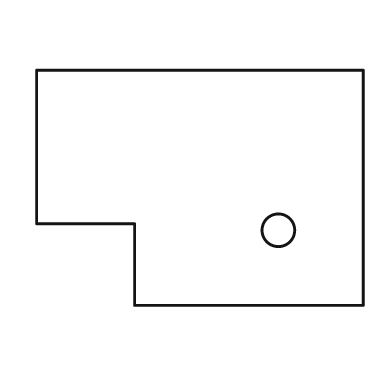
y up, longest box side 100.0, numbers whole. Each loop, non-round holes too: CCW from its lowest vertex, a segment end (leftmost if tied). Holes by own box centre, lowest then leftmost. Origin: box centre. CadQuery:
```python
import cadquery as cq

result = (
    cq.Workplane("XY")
    .moveTo(-20.0, -36.0)
    .lineTo(50.0, -36.0)
    .lineTo(50.0, 36.0)
    .lineTo(-50.0, 36.0)
    .lineTo(-50.0, -11.0)
    .lineTo(-20.0, -11.0)
    .close()
    .moveTo(24.0, -13.0)
    .circle(5.0)
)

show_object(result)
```